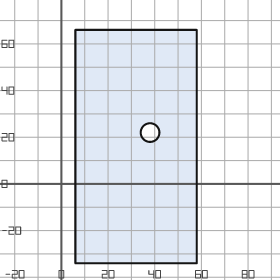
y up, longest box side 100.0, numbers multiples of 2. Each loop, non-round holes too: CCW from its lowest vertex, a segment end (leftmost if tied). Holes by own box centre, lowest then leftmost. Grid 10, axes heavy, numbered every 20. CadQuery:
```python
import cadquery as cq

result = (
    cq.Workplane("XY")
    .moveTo(6.0, -34.0)
    .lineTo(58.0, -34.0)
    .lineTo(58.0, 66.0)
    .lineTo(6.0, 66.0)
    .close()
    .moveTo(38.0, 22.0)
    .circle(4.0)
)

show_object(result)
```